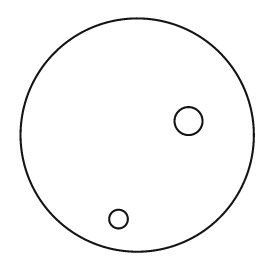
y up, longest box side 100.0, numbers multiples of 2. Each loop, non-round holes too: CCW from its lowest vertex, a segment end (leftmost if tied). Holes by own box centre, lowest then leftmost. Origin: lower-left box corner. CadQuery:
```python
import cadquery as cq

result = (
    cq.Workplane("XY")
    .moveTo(50.0, 50.0)
    .circle(50.0)
    .moveTo(42.0, 14.0)
    .circle(4.0)
    .moveTo(72.0, 56.0)
    .circle(6.0)
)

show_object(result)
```